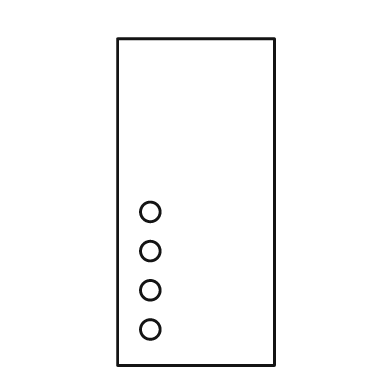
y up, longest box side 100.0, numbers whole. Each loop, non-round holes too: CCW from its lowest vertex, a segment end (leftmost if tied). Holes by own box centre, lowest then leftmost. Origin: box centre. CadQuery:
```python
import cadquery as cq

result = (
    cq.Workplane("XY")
    .moveTo(-24.0, -50.0)
    .lineTo(24.0, -50.0)
    .lineTo(24.0, 50.0)
    .lineTo(-24.0, 50.0)
    .close()
    .moveTo(-14.0, -39.0)
    .circle(3.0)
    .moveTo(-14.0, -27.0)
    .circle(3.0)
    .moveTo(-14.0, -15.0)
    .circle(3.0)
    .moveTo(-14.0, -3.0)
    .circle(3.0)
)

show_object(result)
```